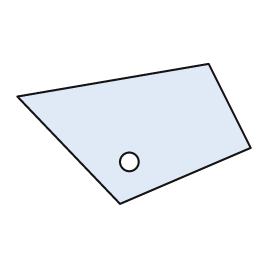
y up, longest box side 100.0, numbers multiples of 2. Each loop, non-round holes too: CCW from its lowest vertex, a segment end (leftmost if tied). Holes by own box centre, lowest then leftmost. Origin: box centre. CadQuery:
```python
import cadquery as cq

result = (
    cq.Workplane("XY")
    .moveTo(-6.0, -30.0)
    .lineTo(50.0, -6.0)
    .lineTo(32.0, 30.0)
    .lineTo(-50.0, 16.0)
    .close()
    .moveTo(-2.0, -12.0)
    .circle(4.0)
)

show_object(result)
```